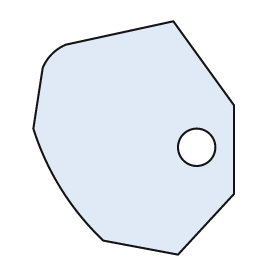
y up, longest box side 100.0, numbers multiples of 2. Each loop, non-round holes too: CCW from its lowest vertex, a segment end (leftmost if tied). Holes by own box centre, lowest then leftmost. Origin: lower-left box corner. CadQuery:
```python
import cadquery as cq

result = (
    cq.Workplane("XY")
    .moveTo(62.0, 0.0)
    .lineTo(86.0, 26.0)
    .lineTo(86.0, 64.0)
    .lineTo(60.0, 100.0)
    .lineTo(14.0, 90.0)
    .threePointArc((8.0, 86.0), (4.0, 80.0))
    .lineTo(0.0, 54.0)
    .threePointArc((12.0, 28.0), (30.0, 6.0))
    .close()
    .moveTo(70.0, 46.0)
    .circle(8.0)
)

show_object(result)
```